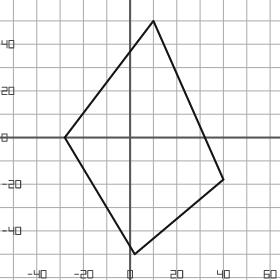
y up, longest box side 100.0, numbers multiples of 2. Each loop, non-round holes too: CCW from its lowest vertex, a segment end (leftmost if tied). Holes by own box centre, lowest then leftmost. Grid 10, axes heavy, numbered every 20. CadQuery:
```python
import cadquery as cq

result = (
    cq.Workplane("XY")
    .moveTo(2.0, -50.0)
    .lineTo(40.0, -18.0)
    .lineTo(10.0, 50.0)
    .lineTo(-28.0, 0.0)
    .close()
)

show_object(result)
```